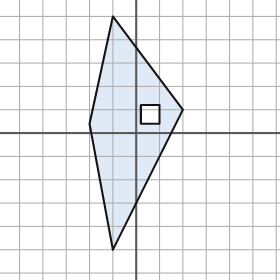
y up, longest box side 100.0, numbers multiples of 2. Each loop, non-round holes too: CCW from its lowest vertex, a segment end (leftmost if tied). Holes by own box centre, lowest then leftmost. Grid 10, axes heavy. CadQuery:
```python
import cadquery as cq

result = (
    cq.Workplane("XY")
    .moveTo(-10.0, -50.0)
    .lineTo(20.0, 10.0)
    .lineTo(-10.0, 50.0)
    .lineTo(-20.0, 4.0)
    .close()
    .moveTo(2.0, 4.0)
    .lineTo(10.0, 4.0)
    .lineTo(10.0, 12.0)
    .lineTo(2.0, 12.0)
    .close()
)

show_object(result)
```